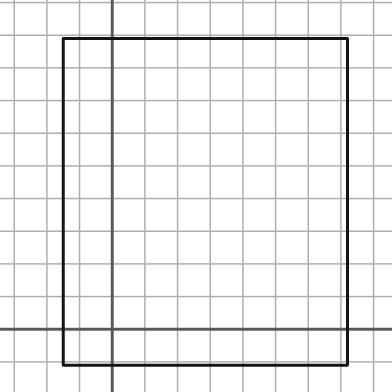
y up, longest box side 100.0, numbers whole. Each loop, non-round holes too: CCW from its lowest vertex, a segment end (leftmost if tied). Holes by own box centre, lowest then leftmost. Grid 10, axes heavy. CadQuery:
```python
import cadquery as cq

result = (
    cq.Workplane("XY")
    .moveTo(-15.0, -11.0)
    .lineTo(72.0, -11.0)
    .lineTo(72.0, 89.0)
    .lineTo(-15.0, 89.0)
    .close()
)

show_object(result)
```